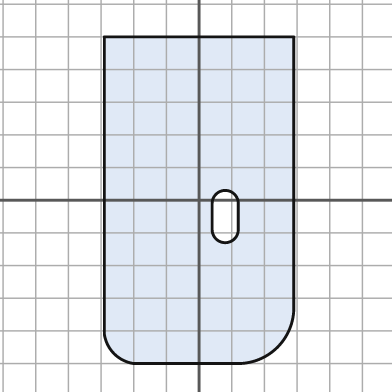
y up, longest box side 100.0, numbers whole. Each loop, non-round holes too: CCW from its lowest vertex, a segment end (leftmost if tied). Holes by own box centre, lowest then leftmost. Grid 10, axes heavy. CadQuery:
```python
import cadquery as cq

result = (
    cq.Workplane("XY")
    .moveTo(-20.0, -50.0)
    .lineTo(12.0, -50.0)
    .threePointArc((24.0, -45.0), (29.0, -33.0))
    .lineTo(29.0, 50.0)
    .lineTo(-29.0, 50.0)
    .lineTo(-29.0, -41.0)
    .threePointArc((-26.0, -47.0), (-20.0, -50.0))
    .close()
    .moveTo(4.0, -9.0)
    .threePointArc((8.0, -13.0), (12.0, -9.0))
    .lineTo(12.0, -1.0)
    .threePointArc((8.0, 3.0), (4.0, -1.0))
    .close()
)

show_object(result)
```